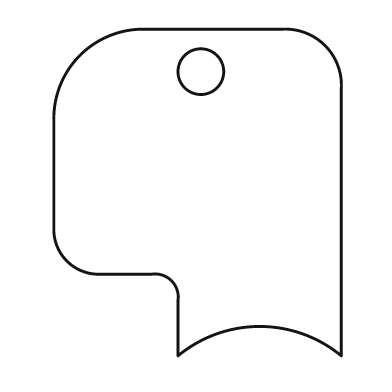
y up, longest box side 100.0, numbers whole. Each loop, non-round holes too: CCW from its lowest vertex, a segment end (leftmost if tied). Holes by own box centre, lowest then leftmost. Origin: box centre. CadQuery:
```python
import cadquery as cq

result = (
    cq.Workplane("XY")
    .moveTo(-6.0, -50.0)
    .threePointArc((19.0, -41.0), (44.0, -50.0))
    .lineTo(44.0, 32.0)
    .threePointArc((39.0, 45.0), (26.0, 50.0))
    .lineTo(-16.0, 50.0)
    .threePointArc((-36.0, 42.0), (-44.0, 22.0))
    .lineTo(-44.0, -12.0)
    .threePointArc((-40.0, -21.0), (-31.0, -25.0))
    .lineTo(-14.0, -25.0)
    .threePointArc((-8.0, -27.0), (-6.0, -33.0))
    .close()
    .moveTo(1.0, 37.0)
    .circle(7.0)
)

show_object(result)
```